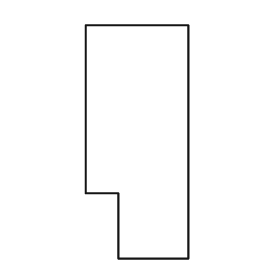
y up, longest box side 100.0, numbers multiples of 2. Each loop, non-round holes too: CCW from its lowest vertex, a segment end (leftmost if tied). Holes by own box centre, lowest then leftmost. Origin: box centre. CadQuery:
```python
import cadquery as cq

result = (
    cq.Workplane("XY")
    .moveTo(-8.0, -50.0)
    .lineTo(22.0, -50.0)
    .lineTo(22.0, 50.0)
    .lineTo(-22.0, 50.0)
    .lineTo(-22.0, -22.0)
    .lineTo(-8.0, -22.0)
    .close()
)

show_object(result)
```